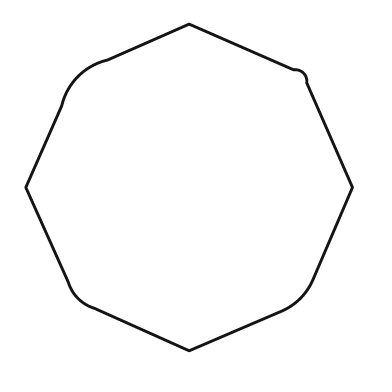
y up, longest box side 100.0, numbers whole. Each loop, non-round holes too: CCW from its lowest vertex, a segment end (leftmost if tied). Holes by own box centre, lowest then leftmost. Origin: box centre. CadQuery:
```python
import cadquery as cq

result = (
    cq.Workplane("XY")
    .moveTo(0.0, -50.0)
    .lineTo(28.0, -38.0)
    .threePointArc((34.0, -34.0), (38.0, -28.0))
    .lineTo(50.0, 0.0)
    .lineTo(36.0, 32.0)
    .threePointArc((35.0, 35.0), (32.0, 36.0))
    .lineTo(0.0, 50.0)
    .lineTo(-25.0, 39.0)
    .threePointArc((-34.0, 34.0), (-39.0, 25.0))
    .lineTo(-50.0, 0.0)
    .lineTo(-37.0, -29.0)
    .threePointArc((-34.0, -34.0), (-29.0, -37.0))
    .close()
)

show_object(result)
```